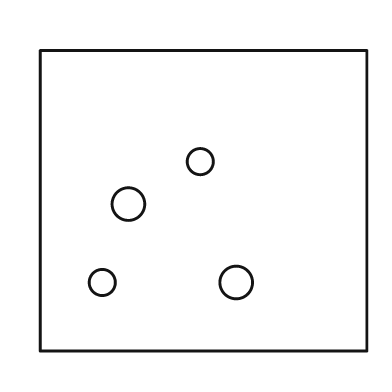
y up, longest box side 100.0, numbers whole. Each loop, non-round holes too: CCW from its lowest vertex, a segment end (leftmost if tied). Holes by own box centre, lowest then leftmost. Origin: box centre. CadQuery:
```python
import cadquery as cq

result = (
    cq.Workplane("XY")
    .moveTo(-50.0, -46.0)
    .lineTo(50.0, -46.0)
    .lineTo(50.0, 46.0)
    .lineTo(-50.0, 46.0)
    .close()
    .moveTo(-31.0, -25.0)
    .circle(4.0)
    .moveTo(10.0, -25.0)
    .circle(5.0)
    .moveTo(-23.0, -1.0)
    .circle(5.0)
    .moveTo(-1.0, 12.0)
    .circle(4.0)
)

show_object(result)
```